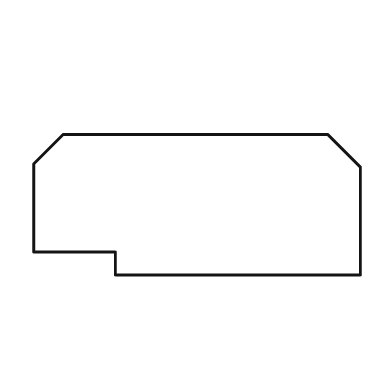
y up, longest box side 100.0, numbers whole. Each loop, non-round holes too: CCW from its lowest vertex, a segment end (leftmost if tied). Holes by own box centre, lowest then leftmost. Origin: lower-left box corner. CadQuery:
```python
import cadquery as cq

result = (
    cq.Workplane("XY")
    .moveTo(25.0, 0.0)
    .lineTo(100.0, 0.0)
    .lineTo(100.0, 33.0)
    .lineTo(90.0, 43.0)
    .lineTo(9.0, 43.0)
    .lineTo(0.0, 34.0)
    .lineTo(0.0, 7.0)
    .lineTo(25.0, 7.0)
    .close()
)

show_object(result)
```